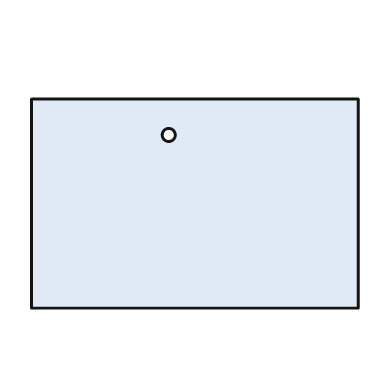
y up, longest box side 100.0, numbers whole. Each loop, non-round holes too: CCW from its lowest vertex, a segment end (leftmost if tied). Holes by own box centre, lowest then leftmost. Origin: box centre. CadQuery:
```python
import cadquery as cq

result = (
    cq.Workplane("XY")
    .moveTo(-50.0, -32.0)
    .lineTo(50.0, -32.0)
    .lineTo(50.0, 32.0)
    .lineTo(-50.0, 32.0)
    .close()
    .moveTo(-8.0, 21.0)
    .circle(2.0)
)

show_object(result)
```